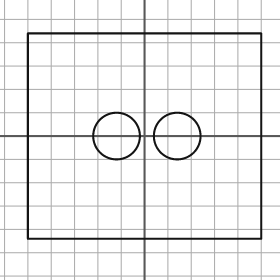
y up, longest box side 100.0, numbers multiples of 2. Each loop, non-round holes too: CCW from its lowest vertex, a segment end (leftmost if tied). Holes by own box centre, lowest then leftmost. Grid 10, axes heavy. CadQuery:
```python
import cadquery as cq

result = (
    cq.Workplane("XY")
    .moveTo(-50.0, -44.0)
    .lineTo(50.0, -44.0)
    .lineTo(50.0, 44.0)
    .lineTo(-50.0, 44.0)
    .close()
    .moveTo(-12.0, 0.0)
    .circle(10.0)
    .moveTo(14.0, 0.0)
    .circle(10.0)
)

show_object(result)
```